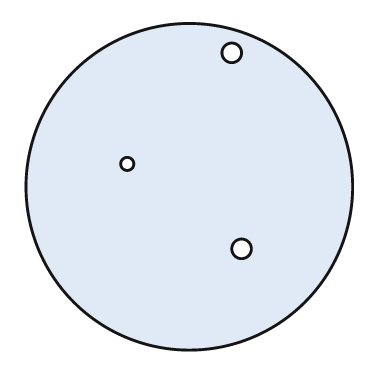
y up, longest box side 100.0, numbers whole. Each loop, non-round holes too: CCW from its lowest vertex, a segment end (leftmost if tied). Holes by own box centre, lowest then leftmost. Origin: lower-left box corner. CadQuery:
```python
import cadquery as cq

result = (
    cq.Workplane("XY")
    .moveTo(50.0, 50.0)
    .circle(50.0)
    .moveTo(66.0, 31.0)
    .circle(3.0)
    .moveTo(31.0, 57.0)
    .circle(2.0)
    .moveTo(63.0, 91.0)
    .circle(3.0)
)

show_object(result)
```